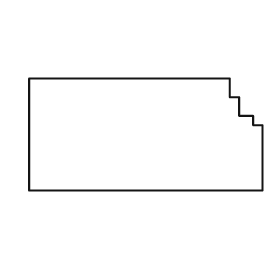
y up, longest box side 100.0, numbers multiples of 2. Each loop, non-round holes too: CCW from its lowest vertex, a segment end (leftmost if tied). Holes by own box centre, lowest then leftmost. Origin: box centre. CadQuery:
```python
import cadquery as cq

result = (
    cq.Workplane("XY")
    .moveTo(-50.0, -24.0)
    .lineTo(50.0, -24.0)
    .lineTo(50.0, 4.0)
    .lineTo(46.0, 4.0)
    .lineTo(46.0, 8.0)
    .lineTo(40.0, 8.0)
    .lineTo(40.0, 16.0)
    .lineTo(36.0, 16.0)
    .lineTo(36.0, 24.0)
    .lineTo(-50.0, 24.0)
    .close()
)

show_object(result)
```